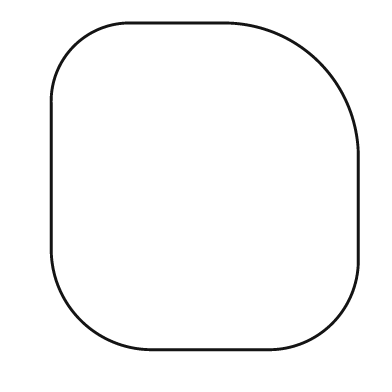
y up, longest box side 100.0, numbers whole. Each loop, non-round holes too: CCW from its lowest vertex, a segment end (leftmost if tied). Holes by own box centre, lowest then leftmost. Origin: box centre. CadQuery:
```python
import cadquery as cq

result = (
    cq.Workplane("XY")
    .moveTo(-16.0, -50.0)
    .lineTo(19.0, -50.0)
    .threePointArc((39.0, -42.0), (47.0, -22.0))
    .lineTo(47.0, 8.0)
    .threePointArc((35.0, 38.0), (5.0, 50.0))
    .lineTo(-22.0, 50.0)
    .threePointArc((-40.0, 43.0), (-47.0, 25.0))
    .lineTo(-47.0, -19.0)
    .threePointArc((-38.0, -41.0), (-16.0, -50.0))
    .close()
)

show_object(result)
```